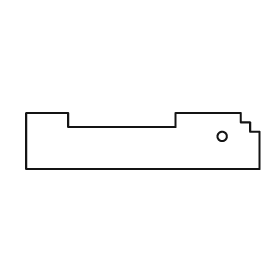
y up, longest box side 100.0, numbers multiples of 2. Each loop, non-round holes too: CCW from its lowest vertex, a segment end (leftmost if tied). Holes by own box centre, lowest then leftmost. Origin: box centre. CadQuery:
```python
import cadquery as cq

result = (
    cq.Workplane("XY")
    .moveTo(-50.0, -12.0)
    .lineTo(50.0, -12.0)
    .lineTo(50.0, 4.0)
    .lineTo(46.0, 4.0)
    .lineTo(46.0, 8.0)
    .lineTo(42.0, 8.0)
    .lineTo(42.0, 12.0)
    .lineTo(14.0, 12.0)
    .lineTo(14.0, 6.0)
    .lineTo(-32.0, 6.0)
    .lineTo(-32.0, 12.0)
    .lineTo(-50.0, 12.0)
    .close()
    .moveTo(34.0, 2.0)
    .circle(2.0)
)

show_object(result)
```